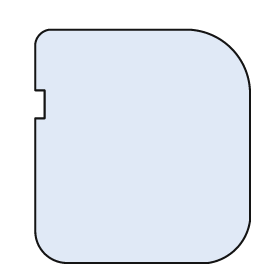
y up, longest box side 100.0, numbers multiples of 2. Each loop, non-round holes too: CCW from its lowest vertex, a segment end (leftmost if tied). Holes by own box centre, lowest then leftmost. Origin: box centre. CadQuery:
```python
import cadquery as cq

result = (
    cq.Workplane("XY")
    .moveTo(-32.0, -50.0)
    .lineTo(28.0, -50.0)
    .threePointArc((40.0, -44.0), (46.0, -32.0))
    .lineTo(46.0, 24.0)
    .threePointArc((38.0, 42.0), (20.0, 50.0))
    .lineTo(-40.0, 50.0)
    .threePointArc((-44.0, 48.0), (-46.0, 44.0))
    .lineTo(-46.0, 24.0)
    .lineTo(-42.0, 24.0)
    .lineTo(-42.0, 12.0)
    .lineTo(-46.0, 12.0)
    .lineTo(-46.0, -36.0)
    .threePointArc((-42.0, -46.0), (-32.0, -50.0))
    .close()
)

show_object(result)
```